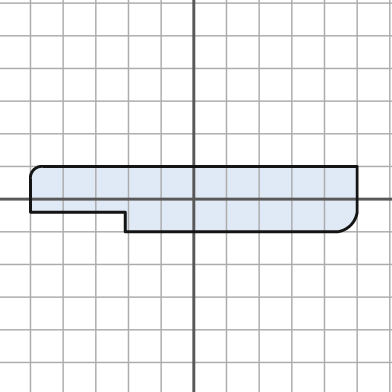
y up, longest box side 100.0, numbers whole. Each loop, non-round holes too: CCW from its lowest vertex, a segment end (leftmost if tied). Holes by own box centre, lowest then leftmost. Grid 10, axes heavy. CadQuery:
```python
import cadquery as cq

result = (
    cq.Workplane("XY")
    .moveTo(-21.0, -10.0)
    .lineTo(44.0, -10.0)
    .threePointArc((48.0, -8.0), (50.0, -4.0))
    .lineTo(50.0, 10.0)
    .lineTo(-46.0, 10.0)
    .threePointArc((-49.0, 9.0), (-50.0, 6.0))
    .lineTo(-50.0, -4.0)
    .lineTo(-21.0, -4.0)
    .close()
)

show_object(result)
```